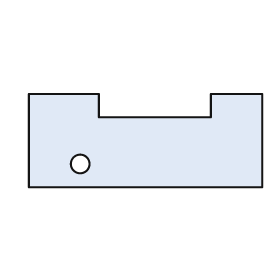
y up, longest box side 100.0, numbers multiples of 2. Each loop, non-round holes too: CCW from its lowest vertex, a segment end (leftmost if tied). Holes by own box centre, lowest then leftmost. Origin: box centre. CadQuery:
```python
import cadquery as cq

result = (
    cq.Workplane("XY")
    .moveTo(-50.0, -20.0)
    .lineTo(50.0, -20.0)
    .lineTo(50.0, 20.0)
    .lineTo(28.0, 20.0)
    .lineTo(28.0, 10.0)
    .lineTo(-20.0, 10.0)
    .lineTo(-20.0, 20.0)
    .lineTo(-50.0, 20.0)
    .close()
    .moveTo(-28.0, -10.0)
    .circle(4.0)
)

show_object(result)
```